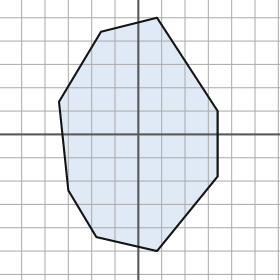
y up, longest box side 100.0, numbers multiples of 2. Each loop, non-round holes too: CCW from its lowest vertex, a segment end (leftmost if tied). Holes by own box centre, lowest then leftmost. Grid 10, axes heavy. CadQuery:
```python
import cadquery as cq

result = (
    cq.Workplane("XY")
    .moveTo(8.0, -50.0)
    .lineTo(34.0, -18.0)
    .lineTo(34.0, 10.0)
    .lineTo(8.0, 50.0)
    .lineTo(-16.0, 44.0)
    .lineTo(-34.0, 14.0)
    .lineTo(-30.0, -24.0)
    .lineTo(-18.0, -44.0)
    .close()
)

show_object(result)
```